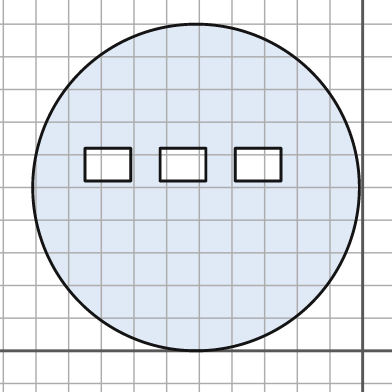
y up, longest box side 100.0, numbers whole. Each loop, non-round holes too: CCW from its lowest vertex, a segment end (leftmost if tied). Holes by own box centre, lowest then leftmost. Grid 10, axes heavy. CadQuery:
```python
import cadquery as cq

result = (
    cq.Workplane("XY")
    .moveTo(-51.0, 50.0)
    .circle(50.0)
    .moveTo(-85.0, 52.0)
    .lineTo(-71.0, 52.0)
    .lineTo(-71.0, 62.0)
    .lineTo(-85.0, 62.0)
    .close()
    .moveTo(-62.0, 52.0)
    .lineTo(-48.0, 52.0)
    .lineTo(-48.0, 62.0)
    .lineTo(-62.0, 62.0)
    .close()
    .moveTo(-39.0, 52.0)
    .lineTo(-25.0, 52.0)
    .lineTo(-25.0, 62.0)
    .lineTo(-39.0, 62.0)
    .close()
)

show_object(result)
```